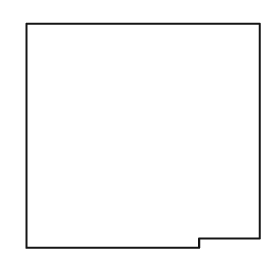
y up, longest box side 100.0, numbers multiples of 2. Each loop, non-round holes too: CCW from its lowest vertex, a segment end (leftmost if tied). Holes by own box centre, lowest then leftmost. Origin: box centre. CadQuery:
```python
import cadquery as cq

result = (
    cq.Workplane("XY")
    .moveTo(-50.0, -48.0)
    .lineTo(24.0, -48.0)
    .lineTo(24.0, -44.0)
    .lineTo(50.0, -44.0)
    .lineTo(50.0, 48.0)
    .lineTo(-50.0, 48.0)
    .close()
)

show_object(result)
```